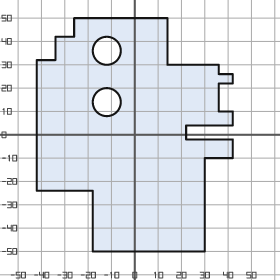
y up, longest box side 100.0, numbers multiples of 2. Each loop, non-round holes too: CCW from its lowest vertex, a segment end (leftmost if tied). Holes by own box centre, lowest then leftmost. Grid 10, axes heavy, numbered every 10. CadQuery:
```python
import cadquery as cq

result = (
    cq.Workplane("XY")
    .moveTo(-18.0, -50.0)
    .lineTo(30.0, -50.0)
    .lineTo(30.0, -10.0)
    .lineTo(42.0, -10.0)
    .lineTo(42.0, -2.0)
    .lineTo(22.0, -2.0)
    .lineTo(22.0, 4.0)
    .lineTo(42.0, 4.0)
    .lineTo(42.0, 10.0)
    .lineTo(36.0, 10.0)
    .lineTo(36.0, 22.0)
    .lineTo(42.0, 22.0)
    .lineTo(42.0, 26.0)
    .lineTo(36.0, 26.0)
    .lineTo(36.0, 30.0)
    .lineTo(14.0, 30.0)
    .lineTo(14.0, 50.0)
    .lineTo(-26.0, 50.0)
    .lineTo(-26.0, 42.0)
    .lineTo(-34.0, 42.0)
    .lineTo(-34.0, 32.0)
    .lineTo(-42.0, 32.0)
    .lineTo(-42.0, -24.0)
    .lineTo(-18.0, -24.0)
    .close()
    .moveTo(-12.0, 14.0)
    .circle(6.0)
    .moveTo(-12.0, 36.0)
    .circle(6.0)
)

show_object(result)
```